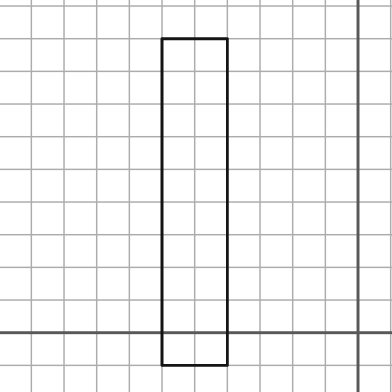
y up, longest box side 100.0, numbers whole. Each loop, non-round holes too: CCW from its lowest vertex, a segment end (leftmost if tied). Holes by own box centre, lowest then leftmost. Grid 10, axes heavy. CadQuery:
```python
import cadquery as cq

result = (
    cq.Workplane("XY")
    .moveTo(-60.0, -10.0)
    .lineTo(-40.0, -10.0)
    .lineTo(-40.0, 90.0)
    .lineTo(-60.0, 90.0)
    .close()
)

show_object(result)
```